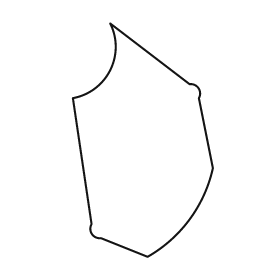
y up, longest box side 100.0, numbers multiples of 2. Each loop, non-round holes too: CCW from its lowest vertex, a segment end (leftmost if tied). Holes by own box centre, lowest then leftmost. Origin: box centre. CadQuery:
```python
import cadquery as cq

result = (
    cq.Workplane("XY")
    .moveTo(2.0, -50.0)
    .threePointArc((20.0, -34.0), (30.0, -12.0))
    .lineTo(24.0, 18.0)
    .threePointArc((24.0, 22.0), (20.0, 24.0))
    .lineTo(-14.0, 50.0)
    .threePointArc((-14.0, 30.0), (-30.0, 18.0))
    .lineTo(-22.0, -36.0)
    .threePointArc((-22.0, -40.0), (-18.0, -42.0))
    .close()
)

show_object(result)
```